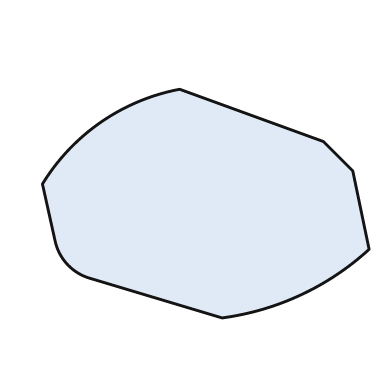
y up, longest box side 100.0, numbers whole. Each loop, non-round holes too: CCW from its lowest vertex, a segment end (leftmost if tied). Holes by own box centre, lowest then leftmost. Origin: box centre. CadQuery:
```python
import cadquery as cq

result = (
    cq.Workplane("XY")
    .moveTo(5.0, -35.0)
    .threePointArc((29.0, -28.0), (50.0, -14.0))
    .lineTo(45.0, 10.0)
    .lineTo(36.0, 19.0)
    .lineTo(-8.0, 35.0)
    .threePointArc((-32.0, 25.0), (-50.0, 6.0))
    .lineTo(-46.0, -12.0)
    .threePointArc((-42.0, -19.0), (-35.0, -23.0))
    .close()
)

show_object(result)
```